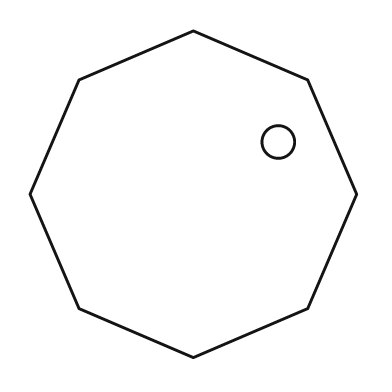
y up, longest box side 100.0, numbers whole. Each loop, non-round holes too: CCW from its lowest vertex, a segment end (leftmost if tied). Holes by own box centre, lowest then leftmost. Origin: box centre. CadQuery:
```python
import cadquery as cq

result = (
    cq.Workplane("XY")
    .moveTo(0.0, -50.0)
    .lineTo(35.0, -35.0)
    .lineTo(50.0, 0.0)
    .lineTo(35.0, 35.0)
    .lineTo(0.0, 50.0)
    .lineTo(-35.0, 35.0)
    .lineTo(-50.0, 0.0)
    .lineTo(-35.0, -35.0)
    .close()
    .moveTo(26.0, 16.0)
    .circle(5.0)
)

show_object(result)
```